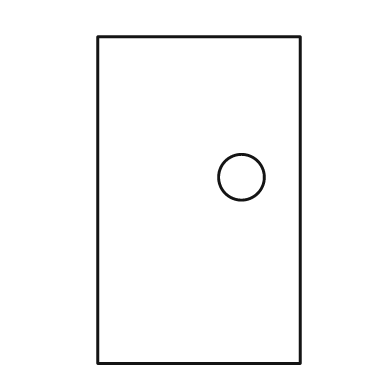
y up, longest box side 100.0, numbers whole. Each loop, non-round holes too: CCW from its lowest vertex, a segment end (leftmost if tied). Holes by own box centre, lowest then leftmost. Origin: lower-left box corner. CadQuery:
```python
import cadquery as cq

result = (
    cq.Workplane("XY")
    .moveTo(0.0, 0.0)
    .lineTo(62.0, 0.0)
    .lineTo(62.0, 100.0)
    .lineTo(0.0, 100.0)
    .close()
    .moveTo(44.0, 57.0)
    .circle(7.0)
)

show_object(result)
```